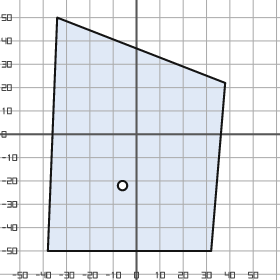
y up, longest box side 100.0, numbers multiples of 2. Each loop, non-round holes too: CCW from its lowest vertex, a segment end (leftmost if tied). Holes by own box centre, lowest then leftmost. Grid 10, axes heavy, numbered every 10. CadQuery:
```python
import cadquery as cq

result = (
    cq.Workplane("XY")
    .moveTo(-38.0, -50.0)
    .lineTo(32.0, -50.0)
    .lineTo(38.0, 22.0)
    .lineTo(-34.0, 50.0)
    .close()
    .moveTo(-6.0, -22.0)
    .circle(2.0)
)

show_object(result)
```